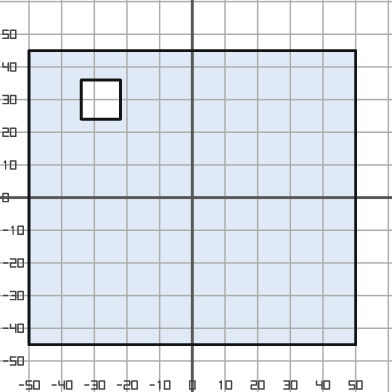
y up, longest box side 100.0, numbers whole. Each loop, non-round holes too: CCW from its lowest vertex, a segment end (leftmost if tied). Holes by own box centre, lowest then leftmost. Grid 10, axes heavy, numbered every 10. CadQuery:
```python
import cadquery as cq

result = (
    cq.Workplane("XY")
    .moveTo(-50.0, -45.0)
    .lineTo(50.0, -45.0)
    .lineTo(50.0, 45.0)
    .lineTo(-50.0, 45.0)
    .close()
    .moveTo(-34.0, 24.0)
    .lineTo(-22.0, 24.0)
    .lineTo(-22.0, 36.0)
    .lineTo(-34.0, 36.0)
    .close()
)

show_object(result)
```